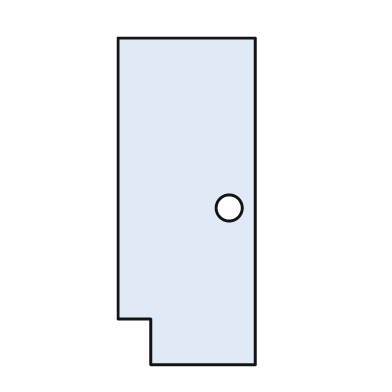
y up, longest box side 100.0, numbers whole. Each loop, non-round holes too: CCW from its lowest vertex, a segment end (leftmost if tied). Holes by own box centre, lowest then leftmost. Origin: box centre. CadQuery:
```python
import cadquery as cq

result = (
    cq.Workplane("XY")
    .moveTo(-11.0, -50.0)
    .lineTo(21.0, -50.0)
    .lineTo(21.0, 50.0)
    .lineTo(-21.0, 50.0)
    .lineTo(-21.0, -36.0)
    .lineTo(-11.0, -36.0)
    .close()
    .moveTo(13.0, -2.0)
    .circle(4.0)
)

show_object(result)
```